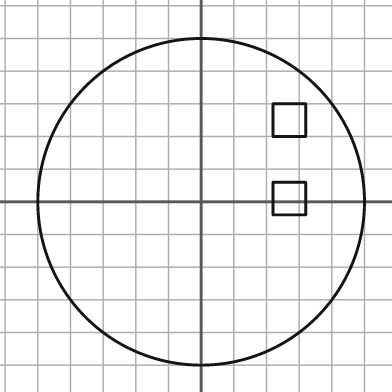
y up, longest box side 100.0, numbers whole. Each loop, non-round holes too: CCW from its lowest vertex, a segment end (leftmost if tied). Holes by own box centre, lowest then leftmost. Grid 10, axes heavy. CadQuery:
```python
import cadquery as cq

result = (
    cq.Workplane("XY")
    .moveTo(0.0, 0.0)
    .circle(50.0)
    .moveTo(22.0, -4.0)
    .lineTo(32.0, -4.0)
    .lineTo(32.0, 6.0)
    .lineTo(22.0, 6.0)
    .close()
    .moveTo(22.0, 20.0)
    .lineTo(32.0, 20.0)
    .lineTo(32.0, 30.0)
    .lineTo(22.0, 30.0)
    .close()
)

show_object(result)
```